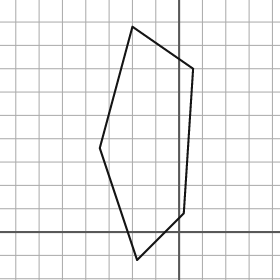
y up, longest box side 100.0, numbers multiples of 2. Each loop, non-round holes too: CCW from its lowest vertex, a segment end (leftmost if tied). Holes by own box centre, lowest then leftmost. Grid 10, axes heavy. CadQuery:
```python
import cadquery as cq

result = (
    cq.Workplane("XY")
    .moveTo(-18.0, -12.0)
    .lineTo(2.0, 8.0)
    .lineTo(6.0, 70.0)
    .lineTo(-20.0, 88.0)
    .lineTo(-34.0, 36.0)
    .close()
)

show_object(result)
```